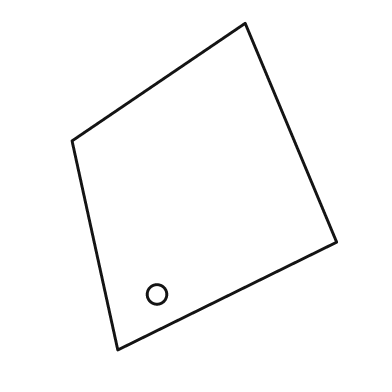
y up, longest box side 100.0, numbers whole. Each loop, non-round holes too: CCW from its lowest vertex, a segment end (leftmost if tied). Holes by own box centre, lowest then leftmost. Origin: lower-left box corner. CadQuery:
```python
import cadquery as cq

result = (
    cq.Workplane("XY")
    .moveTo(14.0, 0.0)
    .lineTo(81.0, 33.0)
    .lineTo(53.0, 100.0)
    .lineTo(0.0, 64.0)
    .close()
    .moveTo(26.0, 17.0)
    .circle(3.0)
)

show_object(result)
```